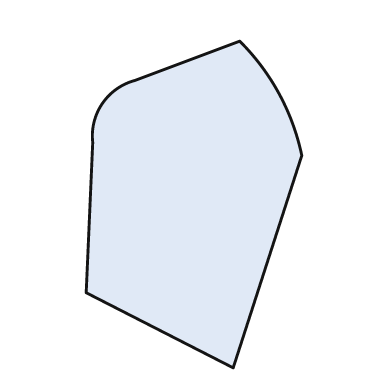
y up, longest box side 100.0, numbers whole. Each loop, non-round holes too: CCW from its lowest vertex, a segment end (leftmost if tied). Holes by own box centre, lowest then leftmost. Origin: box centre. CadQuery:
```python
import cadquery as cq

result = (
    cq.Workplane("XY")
    .moveTo(12.0, -50.0)
    .lineTo(33.0, 15.0)
    .threePointArc((26.0, 34.0), (14.0, 50.0))
    .lineTo(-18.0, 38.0)
    .threePointArc((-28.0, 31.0), (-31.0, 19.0))
    .lineTo(-33.0, -27.0)
    .close()
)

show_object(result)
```